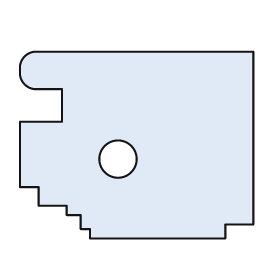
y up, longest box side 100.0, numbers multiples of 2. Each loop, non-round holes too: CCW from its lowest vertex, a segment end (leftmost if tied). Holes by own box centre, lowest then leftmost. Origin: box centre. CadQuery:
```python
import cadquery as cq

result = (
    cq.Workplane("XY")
    .moveTo(-20.0, -40.0)
    .lineTo(38.0, -40.0)
    .lineTo(38.0, -34.0)
    .lineTo(50.0, -34.0)
    .lineTo(50.0, 40.0)
    .lineTo(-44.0, 40.0)
    .threePointArc((-48.0, 38.0), (-50.0, 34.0))
    .lineTo(-50.0, 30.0)
    .threePointArc((-48.0, 26.0), (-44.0, 24.0))
    .lineTo(-32.0, 24.0)
    .lineTo(-32.0, 10.0)
    .lineTo(-50.0, 10.0)
    .lineTo(-50.0, -18.0)
    .lineTo(-42.0, -18.0)
    .lineTo(-42.0, -26.0)
    .lineTo(-30.0, -26.0)
    .lineTo(-30.0, -30.0)
    .lineTo(-24.0, -30.0)
    .lineTo(-24.0, -36.0)
    .lineTo(-20.0, -36.0)
    .close()
    .moveTo(-8.0, -6.0)
    .circle(8.0)
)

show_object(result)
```